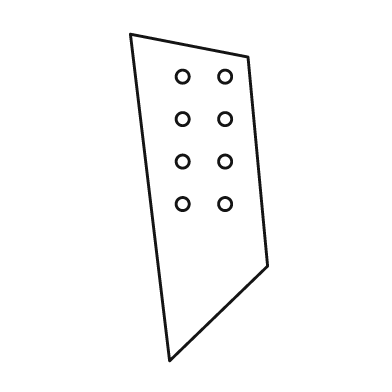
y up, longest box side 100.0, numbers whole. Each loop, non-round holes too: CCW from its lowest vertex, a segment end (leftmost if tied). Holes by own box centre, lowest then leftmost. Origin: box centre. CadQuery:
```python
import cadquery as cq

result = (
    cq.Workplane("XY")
    .moveTo(-9.0, -50.0)
    .lineTo(21.0, -21.0)
    .lineTo(15.0, 43.0)
    .lineTo(-21.0, 50.0)
    .close()
    .moveTo(-5.0, -2.0)
    .circle(2.0)
    .moveTo(8.0, -2.0)
    .circle(2.0)
    .moveTo(-5.0, 11.0)
    .circle(2.0)
    .moveTo(8.0, 11.0)
    .circle(2.0)
    .moveTo(-5.0, 24.0)
    .circle(2.0)
    .moveTo(8.0, 24.0)
    .circle(2.0)
    .moveTo(-5.0, 37.0)
    .circle(2.0)
    .moveTo(8.0, 37.0)
    .circle(2.0)
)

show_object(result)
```